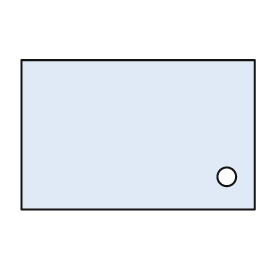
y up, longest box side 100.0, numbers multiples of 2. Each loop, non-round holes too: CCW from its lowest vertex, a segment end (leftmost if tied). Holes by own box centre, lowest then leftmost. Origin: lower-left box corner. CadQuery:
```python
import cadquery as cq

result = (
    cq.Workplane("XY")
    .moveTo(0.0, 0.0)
    .lineTo(100.0, 0.0)
    .lineTo(100.0, 64.0)
    .lineTo(0.0, 64.0)
    .close()
    .moveTo(88.0, 14.0)
    .circle(4.0)
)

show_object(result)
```